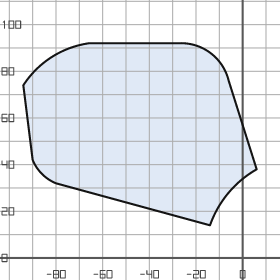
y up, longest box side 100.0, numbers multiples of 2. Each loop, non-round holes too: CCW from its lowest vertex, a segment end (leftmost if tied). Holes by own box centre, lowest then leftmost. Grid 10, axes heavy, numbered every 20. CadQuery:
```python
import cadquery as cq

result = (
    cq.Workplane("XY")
    .moveTo(-14.0, 14.0)
    .threePointArc((-6.0, 28.0), (6.0, 38.0))
    .lineTo(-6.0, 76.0)
    .threePointArc((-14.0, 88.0), (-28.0, 92.0))
    .lineTo(-66.0, 92.0)
    .threePointArc((-82.0, 86.0), (-94.0, 74.0))
    .lineTo(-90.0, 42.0)
    .threePointArc((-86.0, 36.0), (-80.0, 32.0))
    .close()
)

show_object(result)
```